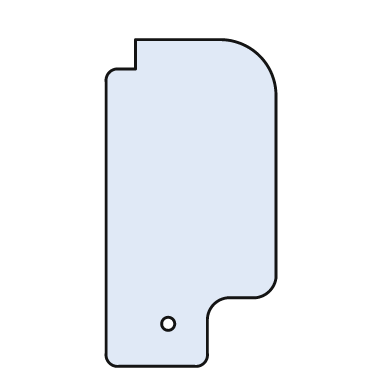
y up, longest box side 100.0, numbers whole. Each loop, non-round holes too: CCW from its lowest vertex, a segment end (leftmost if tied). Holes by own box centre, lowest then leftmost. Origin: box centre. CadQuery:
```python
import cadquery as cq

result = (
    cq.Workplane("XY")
    .moveTo(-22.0, -50.0)
    .lineTo(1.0, -50.0)
    .threePointArc((4.0, -49.0), (5.0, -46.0))
    .lineTo(5.0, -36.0)
    .threePointArc((7.0, -31.0), (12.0, -29.0))
    .lineTo(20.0, -29.0)
    .threePointArc((24.0, -27.0), (26.0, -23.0))
    .lineTo(26.0, 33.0)
    .threePointArc((21.0, 45.0), (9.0, 50.0))
    .lineTo(-17.0, 50.0)
    .lineTo(-17.0, 41.0)
    .lineTo(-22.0, 41.0)
    .threePointArc((-25.0, 40.0), (-26.0, 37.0))
    .lineTo(-26.0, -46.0)
    .threePointArc((-25.0, -49.0), (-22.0, -50.0))
    .close()
    .moveTo(-7.0, -37.0)
    .circle(2.0)
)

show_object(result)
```